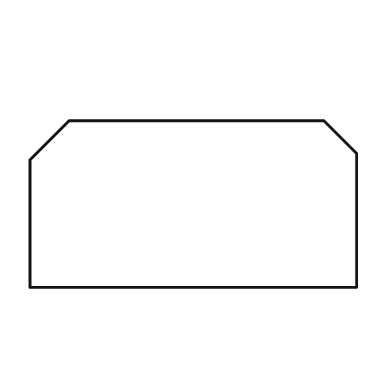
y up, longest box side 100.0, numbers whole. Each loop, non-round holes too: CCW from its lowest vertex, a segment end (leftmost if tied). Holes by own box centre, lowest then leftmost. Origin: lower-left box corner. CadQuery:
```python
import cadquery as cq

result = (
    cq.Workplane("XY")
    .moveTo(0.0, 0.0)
    .lineTo(100.0, 0.0)
    .lineTo(100.0, 41.0)
    .lineTo(90.0, 51.0)
    .lineTo(12.0, 51.0)
    .lineTo(0.0, 39.0)
    .close()
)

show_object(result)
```